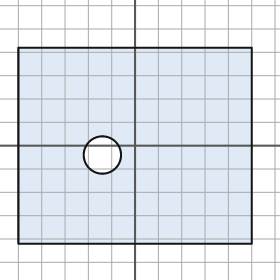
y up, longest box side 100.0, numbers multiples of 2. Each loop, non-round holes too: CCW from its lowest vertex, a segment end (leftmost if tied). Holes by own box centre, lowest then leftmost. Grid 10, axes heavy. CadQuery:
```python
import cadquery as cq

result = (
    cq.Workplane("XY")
    .moveTo(-50.0, -42.0)
    .lineTo(50.0, -42.0)
    .lineTo(50.0, 42.0)
    .lineTo(-50.0, 42.0)
    .close()
    .moveTo(-14.0, -4.0)
    .circle(8.0)
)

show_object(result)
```